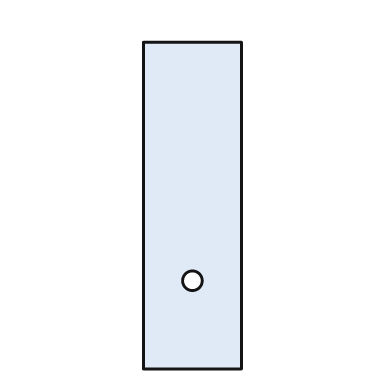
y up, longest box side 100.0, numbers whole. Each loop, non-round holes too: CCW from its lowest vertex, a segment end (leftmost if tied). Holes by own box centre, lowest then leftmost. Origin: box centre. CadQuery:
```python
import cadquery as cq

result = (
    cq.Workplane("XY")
    .moveTo(-15.0, -50.0)
    .lineTo(15.0, -50.0)
    .lineTo(15.0, 50.0)
    .lineTo(-15.0, 50.0)
    .close()
    .moveTo(0.0, -23.0)
    .circle(3.0)
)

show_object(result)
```